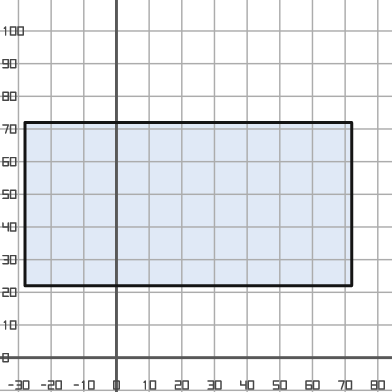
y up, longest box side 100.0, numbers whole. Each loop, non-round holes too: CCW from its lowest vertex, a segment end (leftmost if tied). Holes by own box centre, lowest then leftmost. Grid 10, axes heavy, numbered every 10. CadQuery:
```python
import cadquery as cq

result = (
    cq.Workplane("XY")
    .moveTo(-28.0, 22.0)
    .lineTo(72.0, 22.0)
    .lineTo(72.0, 72.0)
    .lineTo(-28.0, 72.0)
    .close()
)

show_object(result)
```